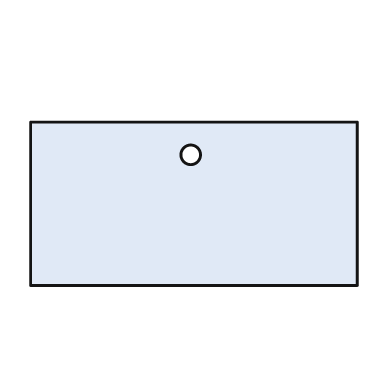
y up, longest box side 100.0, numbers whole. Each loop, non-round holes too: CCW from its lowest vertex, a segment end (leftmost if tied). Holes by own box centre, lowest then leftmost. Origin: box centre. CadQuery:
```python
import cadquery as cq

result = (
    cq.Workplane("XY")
    .moveTo(-50.0, -25.0)
    .lineTo(50.0, -25.0)
    .lineTo(50.0, 25.0)
    .lineTo(-50.0, 25.0)
    .close()
    .moveTo(-1.0, 15.0)
    .circle(3.0)
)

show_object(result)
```